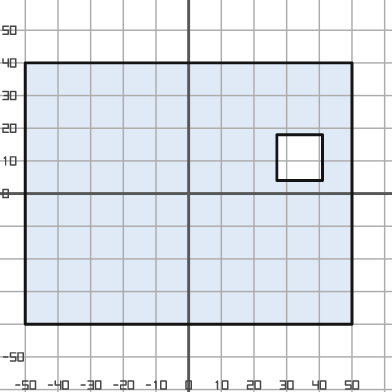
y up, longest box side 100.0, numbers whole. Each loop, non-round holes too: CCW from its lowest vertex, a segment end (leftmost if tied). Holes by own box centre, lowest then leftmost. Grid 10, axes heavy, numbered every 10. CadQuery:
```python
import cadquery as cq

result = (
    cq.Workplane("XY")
    .moveTo(-50.0, -40.0)
    .lineTo(50.0, -40.0)
    .lineTo(50.0, 40.0)
    .lineTo(-50.0, 40.0)
    .close()
    .moveTo(27.0, 4.0)
    .lineTo(41.0, 4.0)
    .lineTo(41.0, 18.0)
    .lineTo(27.0, 18.0)
    .close()
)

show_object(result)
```